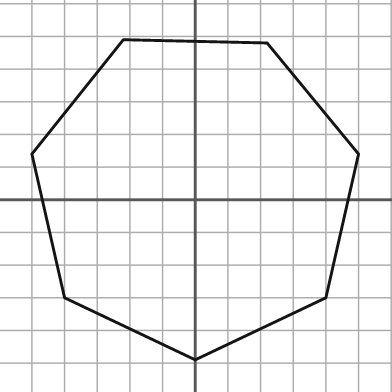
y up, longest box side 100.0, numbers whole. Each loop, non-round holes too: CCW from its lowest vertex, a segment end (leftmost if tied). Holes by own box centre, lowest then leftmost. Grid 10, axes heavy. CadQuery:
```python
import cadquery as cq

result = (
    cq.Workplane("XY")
    .moveTo(0.0, -49.0)
    .lineTo(40.0, -30.0)
    .lineTo(50.0, 14.0)
    .lineTo(22.0, 48.0)
    .lineTo(-22.0, 49.0)
    .lineTo(-50.0, 14.0)
    .lineTo(-40.0, -30.0)
    .close()
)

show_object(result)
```